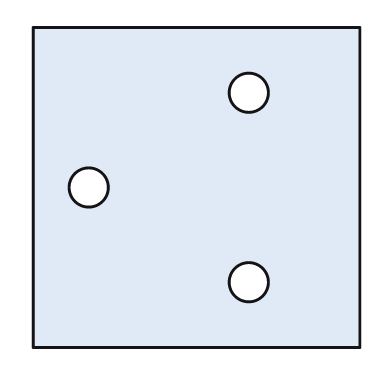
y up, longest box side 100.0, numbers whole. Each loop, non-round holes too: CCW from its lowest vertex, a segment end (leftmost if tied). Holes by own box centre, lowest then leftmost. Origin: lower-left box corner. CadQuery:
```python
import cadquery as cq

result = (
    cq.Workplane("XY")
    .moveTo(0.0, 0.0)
    .lineTo(100.0, 0.0)
    .lineTo(100.0, 98.0)
    .lineTo(0.0, 98.0)
    .close()
    .moveTo(66.0, 20.0)
    .circle(6.0)
    .moveTo(17.0, 49.0)
    .circle(6.0)
    .moveTo(66.0, 78.0)
    .circle(6.0)
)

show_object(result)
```